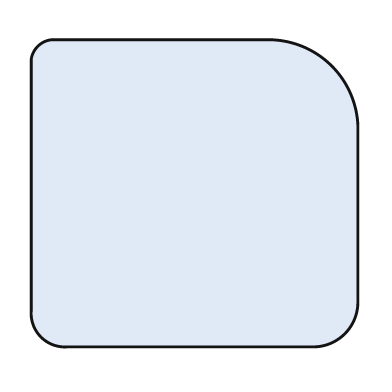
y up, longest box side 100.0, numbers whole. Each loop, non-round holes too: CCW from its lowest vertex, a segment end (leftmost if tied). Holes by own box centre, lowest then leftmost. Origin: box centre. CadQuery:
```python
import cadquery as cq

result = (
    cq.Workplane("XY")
    .moveTo(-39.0, -47.0)
    .lineTo(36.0, -47.0)
    .threePointArc((46.0, -43.0), (50.0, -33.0))
    .lineTo(50.0, 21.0)
    .threePointArc((42.0, 39.0), (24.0, 47.0))
    .lineTo(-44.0, 47.0)
    .threePointArc((-48.0, 45.0), (-50.0, 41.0))
    .lineTo(-50.0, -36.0)
    .threePointArc((-47.0, -44.0), (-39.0, -47.0))
    .close()
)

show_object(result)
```